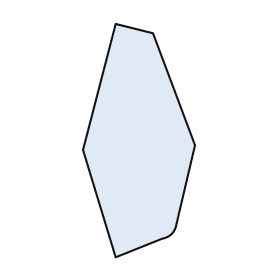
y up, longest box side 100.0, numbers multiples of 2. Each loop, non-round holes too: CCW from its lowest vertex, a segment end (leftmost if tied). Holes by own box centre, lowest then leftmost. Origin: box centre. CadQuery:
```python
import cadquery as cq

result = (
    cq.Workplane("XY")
    .moveTo(-10.0, -50.0)
    .lineTo(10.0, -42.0)
    .threePointArc((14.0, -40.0), (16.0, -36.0))
    .lineTo(24.0, -2.0)
    .lineTo(6.0, 46.0)
    .lineTo(-10.0, 50.0)
    .lineTo(-24.0, -4.0)
    .close()
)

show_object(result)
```